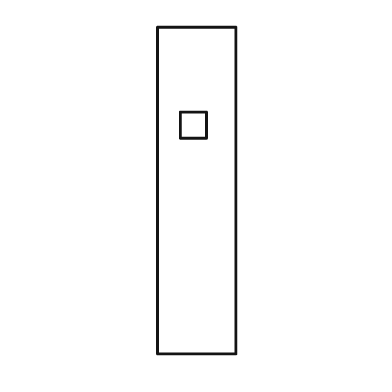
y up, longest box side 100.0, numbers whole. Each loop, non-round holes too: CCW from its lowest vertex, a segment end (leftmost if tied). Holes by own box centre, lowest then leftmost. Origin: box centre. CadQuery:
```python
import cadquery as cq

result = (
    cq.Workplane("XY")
    .moveTo(-12.0, -50.0)
    .lineTo(12.0, -50.0)
    .lineTo(12.0, 50.0)
    .lineTo(-12.0, 50.0)
    .close()
    .moveTo(-5.0, 16.0)
    .lineTo(3.0, 16.0)
    .lineTo(3.0, 24.0)
    .lineTo(-5.0, 24.0)
    .close()
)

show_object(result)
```